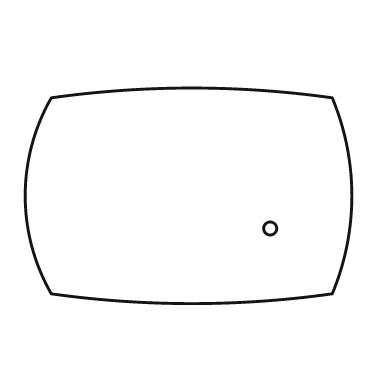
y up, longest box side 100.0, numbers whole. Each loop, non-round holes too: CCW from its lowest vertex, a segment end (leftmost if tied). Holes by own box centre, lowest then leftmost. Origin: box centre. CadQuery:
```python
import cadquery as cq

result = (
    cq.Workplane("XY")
    .moveTo(-42.0, -30.0)
    .threePointArc((1.0, -33.0), (44.0, -30.0))
    .threePointArc((50.0, 0.0), (44.0, 30.0))
    .threePointArc((1.0, 33.0), (-42.0, 30.0))
    .threePointArc((-50.0, 0.0), (-42.0, -30.0))
    .close()
    .moveTo(25.0, -10.0)
    .circle(2.0)
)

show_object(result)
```